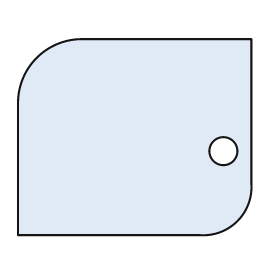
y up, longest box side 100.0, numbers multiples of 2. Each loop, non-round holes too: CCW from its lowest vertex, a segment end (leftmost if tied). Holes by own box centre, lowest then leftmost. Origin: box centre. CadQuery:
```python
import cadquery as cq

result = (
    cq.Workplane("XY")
    .moveTo(-50.0, -42.0)
    .lineTo(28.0, -42.0)
    .threePointArc((44.0, -36.0), (50.0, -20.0))
    .lineTo(50.0, 42.0)
    .lineTo(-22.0, 42.0)
    .threePointArc((-42.0, 34.0), (-50.0, 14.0))
    .close()
    .moveTo(38.0, -6.0)
    .circle(6.0)
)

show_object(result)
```